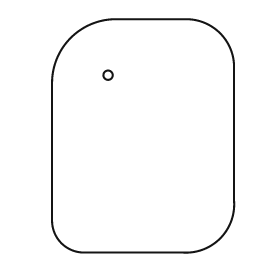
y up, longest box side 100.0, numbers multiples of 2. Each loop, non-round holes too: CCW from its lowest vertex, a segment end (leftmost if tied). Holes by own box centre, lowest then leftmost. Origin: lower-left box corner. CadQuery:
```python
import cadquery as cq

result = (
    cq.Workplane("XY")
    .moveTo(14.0, 0.0)
    .lineTo(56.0, 0.0)
    .threePointArc((72.0, 6.0), (78.0, 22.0))
    .lineTo(78.0, 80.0)
    .threePointArc((72.0, 94.0), (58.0, 100.0))
    .lineTo(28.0, 100.0)
    .threePointArc((8.0, 92.0), (0.0, 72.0))
    .lineTo(0.0, 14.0)
    .threePointArc((4.0, 4.0), (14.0, 0.0))
    .close()
    .moveTo(24.0, 76.0)
    .circle(2.0)
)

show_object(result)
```